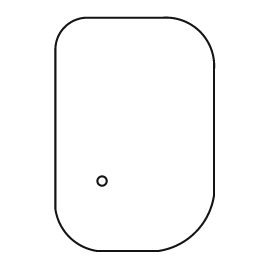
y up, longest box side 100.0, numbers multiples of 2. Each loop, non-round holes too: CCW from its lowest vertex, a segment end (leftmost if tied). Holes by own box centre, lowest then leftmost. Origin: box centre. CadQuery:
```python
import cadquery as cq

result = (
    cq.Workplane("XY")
    .moveTo(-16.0, -50.0)
    .lineTo(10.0, -50.0)
    .threePointArc((26.0, -42.0), (34.0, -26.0))
    .lineTo(34.0, 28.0)
    .threePointArc((28.0, 44.0), (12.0, 50.0))
    .lineTo(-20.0, 50.0)
    .threePointArc((-30.0, 46.0), (-34.0, 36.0))
    .lineTo(-34.0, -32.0)
    .threePointArc((-28.0, -44.0), (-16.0, -50.0))
    .close()
    .moveTo(-14.0, -20.0)
    .circle(2.0)
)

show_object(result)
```